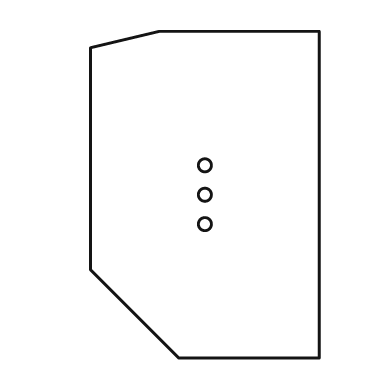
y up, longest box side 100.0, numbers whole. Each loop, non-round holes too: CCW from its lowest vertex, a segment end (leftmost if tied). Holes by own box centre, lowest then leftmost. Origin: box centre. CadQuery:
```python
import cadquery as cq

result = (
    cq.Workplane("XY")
    .moveTo(-8.0, -50.0)
    .lineTo(35.0, -50.0)
    .lineTo(35.0, 50.0)
    .lineTo(-14.0, 50.0)
    .lineTo(-35.0, 45.0)
    .lineTo(-35.0, -23.0)
    .close()
    .moveTo(0.0, -9.0)
    .circle(2.0)
    .moveTo(0.0, 0.0)
    .circle(2.0)
    .moveTo(0.0, 9.0)
    .circle(2.0)
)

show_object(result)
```